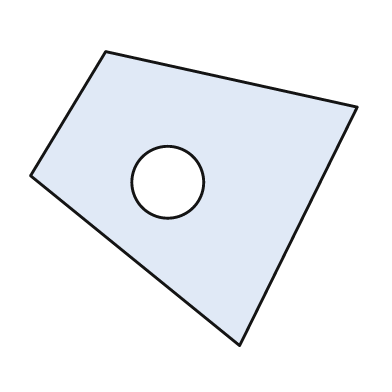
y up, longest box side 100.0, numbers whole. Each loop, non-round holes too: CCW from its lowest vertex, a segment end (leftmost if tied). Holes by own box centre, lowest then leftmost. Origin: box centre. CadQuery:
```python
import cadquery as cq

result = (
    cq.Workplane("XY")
    .moveTo(14.0, -45.0)
    .lineTo(50.0, 28.0)
    .lineTo(-27.0, 45.0)
    .lineTo(-50.0, 7.0)
    .close()
    .moveTo(-8.0, 5.0)
    .circle(11.0)
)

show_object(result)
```